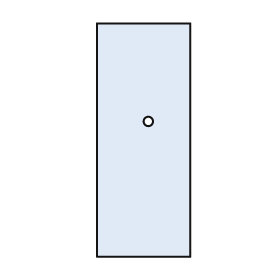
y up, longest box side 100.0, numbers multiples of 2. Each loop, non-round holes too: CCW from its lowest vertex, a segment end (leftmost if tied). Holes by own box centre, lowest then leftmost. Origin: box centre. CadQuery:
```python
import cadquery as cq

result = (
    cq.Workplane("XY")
    .moveTo(-20.0, -50.0)
    .lineTo(20.0, -50.0)
    .lineTo(20.0, 50.0)
    .lineTo(-20.0, 50.0)
    .close()
    .moveTo(2.0, 8.0)
    .circle(2.0)
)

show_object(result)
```